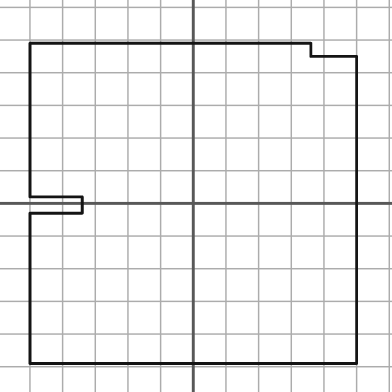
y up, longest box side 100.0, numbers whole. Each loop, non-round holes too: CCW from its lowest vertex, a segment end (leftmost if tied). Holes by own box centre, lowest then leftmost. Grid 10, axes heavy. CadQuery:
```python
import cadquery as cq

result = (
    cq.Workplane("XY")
    .moveTo(-50.0, -49.0)
    .lineTo(50.0, -49.0)
    .lineTo(50.0, 45.0)
    .lineTo(36.0, 45.0)
    .lineTo(36.0, 49.0)
    .lineTo(-50.0, 49.0)
    .lineTo(-50.0, 2.0)
    .lineTo(-34.0, 2.0)
    .lineTo(-34.0, -3.0)
    .lineTo(-50.0, -3.0)
    .close()
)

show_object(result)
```